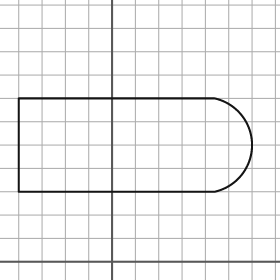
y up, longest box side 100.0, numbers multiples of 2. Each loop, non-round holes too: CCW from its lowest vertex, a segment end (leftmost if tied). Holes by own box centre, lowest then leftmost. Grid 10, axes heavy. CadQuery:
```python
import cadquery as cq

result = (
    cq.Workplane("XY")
    .moveTo(-40.0, 30.0)
    .lineTo(44.0, 30.0)
    .threePointArc((60.0, 50.0), (44.0, 70.0))
    .lineTo(-40.0, 70.0)
    .close()
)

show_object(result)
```